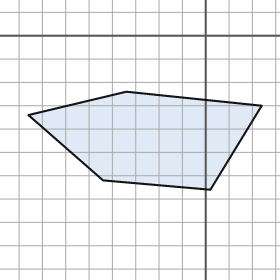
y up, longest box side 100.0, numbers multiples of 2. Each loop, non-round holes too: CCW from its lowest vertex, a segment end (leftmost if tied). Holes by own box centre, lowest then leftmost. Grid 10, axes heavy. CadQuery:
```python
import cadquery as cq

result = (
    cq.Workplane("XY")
    .moveTo(2.0, -66.0)
    .lineTo(24.0, -30.0)
    .lineTo(-34.0, -24.0)
    .lineTo(-76.0, -34.0)
    .lineTo(-44.0, -62.0)
    .close()
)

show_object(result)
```